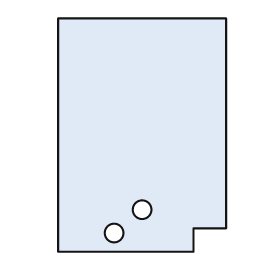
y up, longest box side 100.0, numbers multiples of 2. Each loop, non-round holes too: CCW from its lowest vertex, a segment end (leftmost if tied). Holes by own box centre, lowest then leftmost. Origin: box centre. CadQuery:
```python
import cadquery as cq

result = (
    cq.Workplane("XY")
    .moveTo(-36.0, -50.0)
    .lineTo(22.0, -50.0)
    .lineTo(22.0, -40.0)
    .lineTo(36.0, -40.0)
    .lineTo(36.0, 50.0)
    .lineTo(-36.0, 50.0)
    .close()
    .moveTo(-12.0, -42.0)
    .circle(4.0)
    .moveTo(0.0, -32.0)
    .circle(4.0)
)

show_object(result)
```